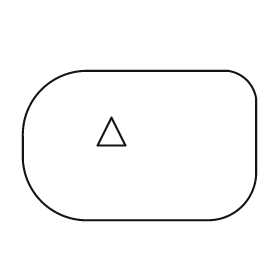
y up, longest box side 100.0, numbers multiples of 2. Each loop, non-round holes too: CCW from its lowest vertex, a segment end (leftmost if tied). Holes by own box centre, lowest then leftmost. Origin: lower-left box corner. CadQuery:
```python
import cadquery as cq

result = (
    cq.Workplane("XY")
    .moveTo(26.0, 0.0)
    .lineTo(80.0, 0.0)
    .threePointArc((94.0, 6.0), (100.0, 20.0))
    .lineTo(100.0, 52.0)
    .threePointArc((96.0, 60.0), (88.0, 64.0))
    .lineTo(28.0, 64.0)
    .threePointArc((8.0, 56.0), (0.0, 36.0))
    .lineTo(0.0, 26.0)
    .threePointArc((8.0, 8.0), (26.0, 0.0))
    .close()
    .moveTo(32.0, 32.0)
    .lineTo(44.0, 32.0)
    .lineTo(38.0, 44.0)
    .close()
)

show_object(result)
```